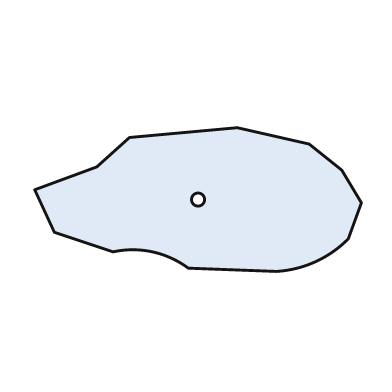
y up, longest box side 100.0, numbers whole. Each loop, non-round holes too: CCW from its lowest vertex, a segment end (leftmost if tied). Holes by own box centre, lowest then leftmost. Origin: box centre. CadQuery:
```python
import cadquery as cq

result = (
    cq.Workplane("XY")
    .moveTo(24.0, -22.0)
    .threePointArc((36.0, -19.0), (46.0, -12.0))
    .lineTo(50.0, -1.0)
    .lineTo(44.0, 9.0)
    .lineTo(34.0, 17.0)
    .lineTo(12.0, 22.0)
    .lineTo(-21.0, 19.0)
    .lineTo(-31.0, 10.0)
    .lineTo(-50.0, 3.0)
    .lineTo(-44.0, -10.0)
    .lineTo(-26.0, -16.0)
    .threePointArc((-14.0, -16.0), (-3.0, -21.0))
    .close()
    .moveTo(0.0, 0.0)
    .circle(2.0)
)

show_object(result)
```